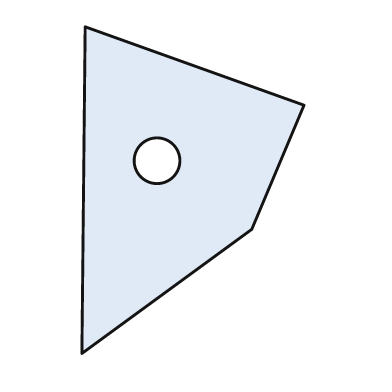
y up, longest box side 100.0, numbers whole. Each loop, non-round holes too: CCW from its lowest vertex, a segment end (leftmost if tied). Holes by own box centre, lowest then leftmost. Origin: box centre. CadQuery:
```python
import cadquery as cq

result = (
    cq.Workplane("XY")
    .moveTo(-34.0, -50.0)
    .lineTo(18.0, -12.0)
    .lineTo(34.0, 26.0)
    .lineTo(-33.0, 50.0)
    .close()
    .moveTo(-11.0, 9.0)
    .circle(7.0)
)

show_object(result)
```